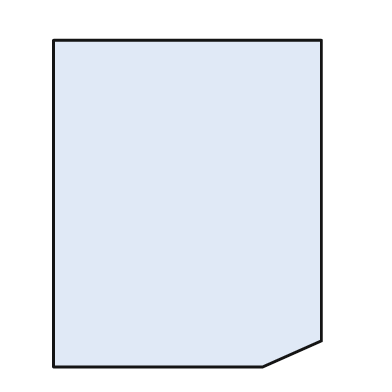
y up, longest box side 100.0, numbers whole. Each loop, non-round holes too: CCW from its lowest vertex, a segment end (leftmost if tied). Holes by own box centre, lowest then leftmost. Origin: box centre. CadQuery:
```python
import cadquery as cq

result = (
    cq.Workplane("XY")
    .moveTo(-41.0, -50.0)
    .lineTo(23.0, -50.0)
    .lineTo(41.0, -42.0)
    .lineTo(41.0, 50.0)
    .lineTo(-41.0, 50.0)
    .close()
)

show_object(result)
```